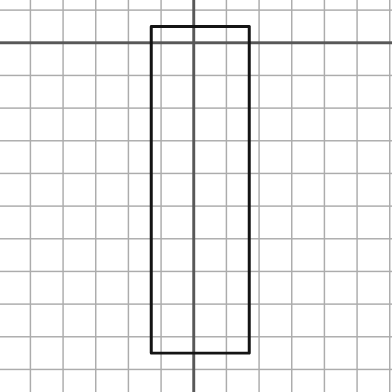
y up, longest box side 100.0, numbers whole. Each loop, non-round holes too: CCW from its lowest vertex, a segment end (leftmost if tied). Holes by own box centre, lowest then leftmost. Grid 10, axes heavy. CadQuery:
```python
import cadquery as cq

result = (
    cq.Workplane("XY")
    .moveTo(-13.0, -95.0)
    .lineTo(17.0, -95.0)
    .lineTo(17.0, 5.0)
    .lineTo(-13.0, 5.0)
    .close()
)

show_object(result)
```